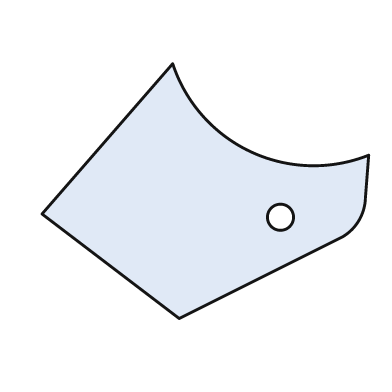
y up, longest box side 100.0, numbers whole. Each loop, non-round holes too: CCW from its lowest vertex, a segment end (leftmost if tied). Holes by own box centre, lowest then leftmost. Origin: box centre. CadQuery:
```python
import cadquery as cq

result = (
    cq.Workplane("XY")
    .moveTo(-8.0, -39.0)
    .lineTo(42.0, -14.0)
    .threePointArc((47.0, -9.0), (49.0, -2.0))
    .lineTo(50.0, 11.0)
    .threePointArc((14.0, 12.0), (-10.0, 39.0))
    .lineTo(-50.0, -7.0)
    .close()
    .moveTo(23.0, -8.0)
    .circle(4.0)
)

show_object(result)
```